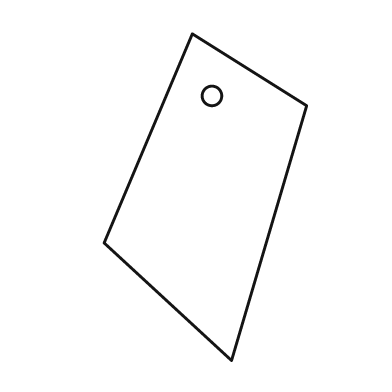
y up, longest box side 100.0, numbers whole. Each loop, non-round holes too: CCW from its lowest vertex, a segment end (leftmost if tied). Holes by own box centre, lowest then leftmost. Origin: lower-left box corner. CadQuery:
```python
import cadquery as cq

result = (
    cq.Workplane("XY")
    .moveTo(39.0, 0.0)
    .lineTo(62.0, 78.0)
    .lineTo(27.0, 100.0)
    .lineTo(0.0, 36.0)
    .close()
    .moveTo(33.0, 81.0)
    .circle(3.0)
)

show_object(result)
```